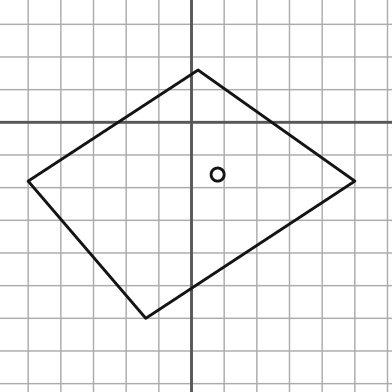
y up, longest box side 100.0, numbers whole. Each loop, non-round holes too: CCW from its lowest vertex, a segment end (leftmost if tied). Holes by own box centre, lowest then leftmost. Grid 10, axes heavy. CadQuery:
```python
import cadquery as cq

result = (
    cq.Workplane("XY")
    .moveTo(-14.0, -60.0)
    .lineTo(50.0, -18.0)
    .lineTo(2.0, 16.0)
    .lineTo(-50.0, -18.0)
    .close()
    .moveTo(8.0, -16.0)
    .circle(2.0)
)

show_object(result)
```